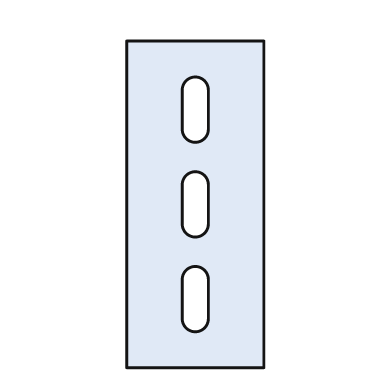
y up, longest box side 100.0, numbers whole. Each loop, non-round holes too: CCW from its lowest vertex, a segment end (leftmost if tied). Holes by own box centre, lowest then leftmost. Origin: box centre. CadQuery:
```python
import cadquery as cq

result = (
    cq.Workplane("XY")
    .moveTo(-21.0, -50.0)
    .lineTo(21.0, -50.0)
    .lineTo(21.0, 50.0)
    .lineTo(-21.0, 50.0)
    .close()
    .moveTo(-4.0, -35.0)
    .threePointArc((0.0, -39.0), (4.0, -35.0))
    .lineTo(4.0, -23.0)
    .threePointArc((0.0, -19.0), (-4.0, -23.0))
    .close()
    .moveTo(-4.0, -6.0)
    .threePointArc((0.0, -10.0), (4.0, -6.0))
    .lineTo(4.0, 6.0)
    .threePointArc((0.0, 10.0), (-4.0, 6.0))
    .close()
    .moveTo(-4.0, 23.0)
    .threePointArc((0.0, 19.0), (4.0, 23.0))
    .lineTo(4.0, 35.0)
    .threePointArc((0.0, 39.0), (-4.0, 35.0))
    .close()
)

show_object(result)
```